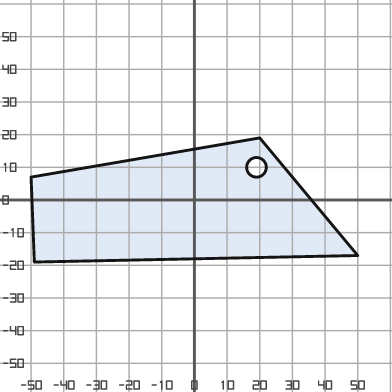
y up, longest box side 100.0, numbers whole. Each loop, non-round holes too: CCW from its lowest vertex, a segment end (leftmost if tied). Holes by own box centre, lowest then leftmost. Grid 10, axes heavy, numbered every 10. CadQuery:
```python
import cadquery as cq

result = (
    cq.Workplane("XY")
    .moveTo(-49.0, -19.0)
    .lineTo(50.0, -17.0)
    .lineTo(20.0, 19.0)
    .lineTo(-50.0, 7.0)
    .close()
    .moveTo(19.0, 10.0)
    .circle(3.0)
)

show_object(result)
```